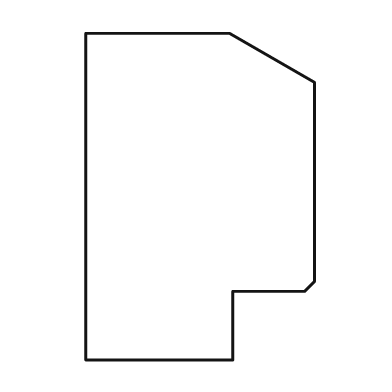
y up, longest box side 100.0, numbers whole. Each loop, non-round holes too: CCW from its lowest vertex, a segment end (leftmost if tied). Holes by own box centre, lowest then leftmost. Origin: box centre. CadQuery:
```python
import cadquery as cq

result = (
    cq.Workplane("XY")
    .moveTo(-35.0, -50.0)
    .lineTo(10.0, -50.0)
    .lineTo(10.0, -29.0)
    .lineTo(32.0, -29.0)
    .lineTo(35.0, -26.0)
    .lineTo(35.0, 35.0)
    .lineTo(9.0, 50.0)
    .lineTo(-35.0, 50.0)
    .close()
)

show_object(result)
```